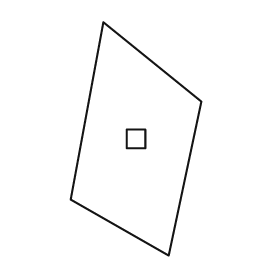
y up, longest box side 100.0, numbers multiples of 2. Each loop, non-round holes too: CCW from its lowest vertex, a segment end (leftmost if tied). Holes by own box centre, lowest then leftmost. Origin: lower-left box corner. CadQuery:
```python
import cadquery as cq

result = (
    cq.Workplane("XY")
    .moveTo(42.0, 0.0)
    .lineTo(56.0, 66.0)
    .lineTo(14.0, 100.0)
    .lineTo(0.0, 24.0)
    .close()
    .moveTo(24.0, 46.0)
    .lineTo(32.0, 46.0)
    .lineTo(32.0, 54.0)
    .lineTo(24.0, 54.0)
    .close()
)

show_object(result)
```